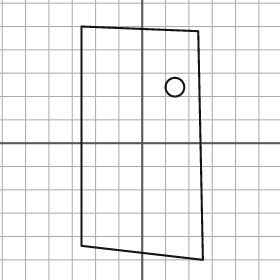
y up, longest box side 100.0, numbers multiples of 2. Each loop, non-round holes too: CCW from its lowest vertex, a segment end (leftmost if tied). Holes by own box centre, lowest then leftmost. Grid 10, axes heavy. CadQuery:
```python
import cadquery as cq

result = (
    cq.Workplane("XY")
    .moveTo(26.0, -50.0)
    .lineTo(24.0, 48.0)
    .lineTo(-26.0, 50.0)
    .lineTo(-26.0, -44.0)
    .close()
    .moveTo(14.0, 24.0)
    .circle(4.0)
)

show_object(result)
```